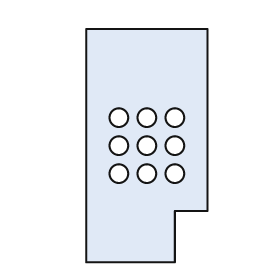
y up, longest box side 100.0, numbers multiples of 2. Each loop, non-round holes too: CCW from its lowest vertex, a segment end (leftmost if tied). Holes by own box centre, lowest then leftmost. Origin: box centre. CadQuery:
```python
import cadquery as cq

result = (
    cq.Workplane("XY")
    .moveTo(-26.0, -50.0)
    .lineTo(12.0, -50.0)
    .lineTo(12.0, -28.0)
    .lineTo(26.0, -28.0)
    .lineTo(26.0, 50.0)
    .lineTo(-26.0, 50.0)
    .close()
    .moveTo(-12.0, -12.0)
    .circle(4.0)
    .moveTo(0.0, -12.0)
    .circle(4.0)
    .moveTo(12.0, -12.0)
    .circle(4.0)
    .moveTo(-12.0, 0.0)
    .circle(4.0)
    .moveTo(0.0, 0.0)
    .circle(4.0)
    .moveTo(12.0, 0.0)
    .circle(4.0)
    .moveTo(-12.0, 12.0)
    .circle(4.0)
    .moveTo(0.0, 12.0)
    .circle(4.0)
    .moveTo(12.0, 12.0)
    .circle(4.0)
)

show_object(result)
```